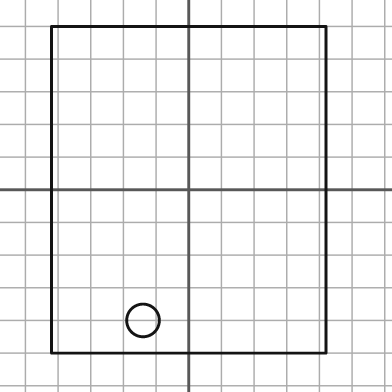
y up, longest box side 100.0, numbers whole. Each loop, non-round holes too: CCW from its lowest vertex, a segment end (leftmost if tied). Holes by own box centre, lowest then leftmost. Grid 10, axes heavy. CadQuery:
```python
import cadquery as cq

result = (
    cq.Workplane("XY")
    .moveTo(-42.0, -50.0)
    .lineTo(42.0, -50.0)
    .lineTo(42.0, 50.0)
    .lineTo(-42.0, 50.0)
    .close()
    .moveTo(-14.0, -40.0)
    .circle(5.0)
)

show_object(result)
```